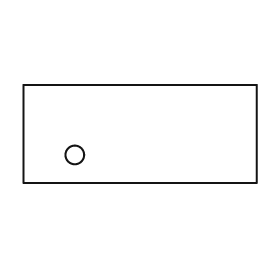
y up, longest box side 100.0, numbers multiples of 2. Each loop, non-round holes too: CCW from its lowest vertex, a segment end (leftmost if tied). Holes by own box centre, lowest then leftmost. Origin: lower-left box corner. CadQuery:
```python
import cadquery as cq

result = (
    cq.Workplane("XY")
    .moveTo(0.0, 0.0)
    .lineTo(100.0, 0.0)
    .lineTo(100.0, 42.0)
    .lineTo(0.0, 42.0)
    .close()
    .moveTo(22.0, 12.0)
    .circle(4.0)
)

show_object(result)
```